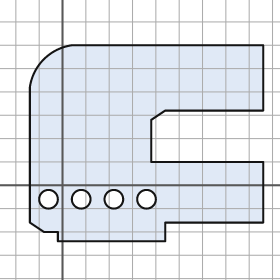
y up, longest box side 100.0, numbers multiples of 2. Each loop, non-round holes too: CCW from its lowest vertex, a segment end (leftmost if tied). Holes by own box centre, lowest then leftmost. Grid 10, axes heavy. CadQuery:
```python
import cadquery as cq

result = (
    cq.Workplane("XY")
    .moveTo(-2.0, -24.0)
    .lineTo(44.0, -24.0)
    .lineTo(44.0, -16.0)
    .lineTo(86.0, -16.0)
    .lineTo(86.0, 10.0)
    .lineTo(38.0, 10.0)
    .lineTo(38.0, 28.0)
    .lineTo(44.0, 32.0)
    .lineTo(86.0, 32.0)
    .lineTo(86.0, 60.0)
    .lineTo(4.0, 60.0)
    .threePointArc((-8.0, 54.0), (-14.0, 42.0))
    .lineTo(-14.0, -16.0)
    .lineTo(-8.0, -20.0)
    .lineTo(-2.0, -20.0)
    .close()
    .moveTo(-6.0, -6.0)
    .circle(4.0)
    .moveTo(8.0, -6.0)
    .circle(4.0)
    .moveTo(22.0, -6.0)
    .circle(4.0)
    .moveTo(36.0, -6.0)
    .circle(4.0)
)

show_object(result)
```